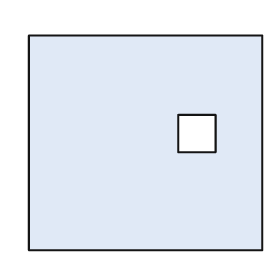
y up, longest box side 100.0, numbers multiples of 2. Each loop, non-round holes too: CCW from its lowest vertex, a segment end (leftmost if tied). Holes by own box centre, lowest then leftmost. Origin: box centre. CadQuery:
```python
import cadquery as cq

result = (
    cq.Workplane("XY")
    .moveTo(-50.0, -46.0)
    .lineTo(50.0, -46.0)
    .lineTo(50.0, 46.0)
    .lineTo(-50.0, 46.0)
    .close()
    .moveTo(14.0, -4.0)
    .lineTo(30.0, -4.0)
    .lineTo(30.0, 12.0)
    .lineTo(14.0, 12.0)
    .close()
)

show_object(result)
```